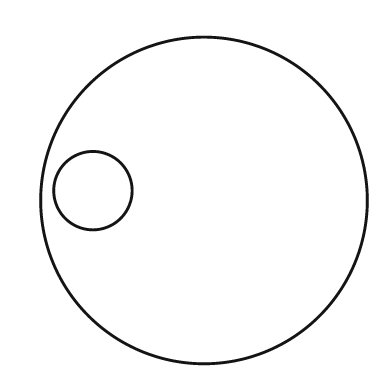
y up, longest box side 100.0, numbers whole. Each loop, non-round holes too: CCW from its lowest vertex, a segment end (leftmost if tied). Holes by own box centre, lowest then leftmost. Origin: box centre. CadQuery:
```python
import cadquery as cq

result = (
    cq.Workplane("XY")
    .moveTo(0.0, 0.0)
    .circle(50.0)
    .moveTo(-34.0, 3.0)
    .circle(12.0)
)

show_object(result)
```